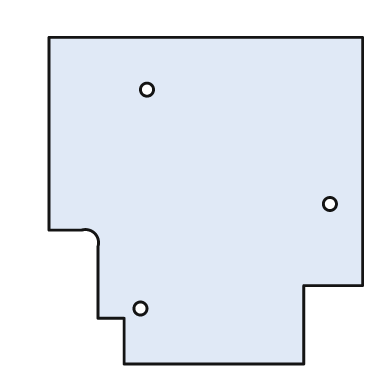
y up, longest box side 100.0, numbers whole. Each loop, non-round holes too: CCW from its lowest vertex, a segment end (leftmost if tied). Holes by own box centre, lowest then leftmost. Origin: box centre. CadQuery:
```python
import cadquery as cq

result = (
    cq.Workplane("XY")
    .moveTo(-25.0, -50.0)
    .lineTo(30.0, -50.0)
    .lineTo(30.0, -26.0)
    .lineTo(48.0, -26.0)
    .lineTo(48.0, 50.0)
    .lineTo(-48.0, 50.0)
    .lineTo(-48.0, -9.0)
    .lineTo(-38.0, -9.0)
    .threePointArc((-34.0, -10.0), (-33.0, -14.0))
    .lineTo(-33.0, -36.0)
    .lineTo(-25.0, -36.0)
    .close()
    .moveTo(-20.0, -33.0)
    .circle(2.0)
    .moveTo(38.0, -1.0)
    .circle(2.0)
    .moveTo(-18.0, 34.0)
    .circle(2.0)
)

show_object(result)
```